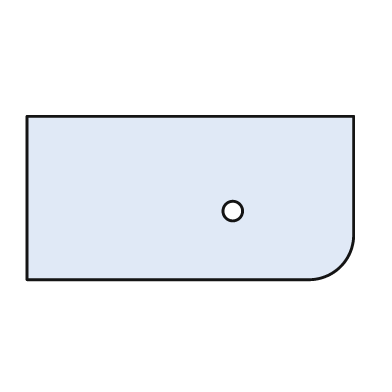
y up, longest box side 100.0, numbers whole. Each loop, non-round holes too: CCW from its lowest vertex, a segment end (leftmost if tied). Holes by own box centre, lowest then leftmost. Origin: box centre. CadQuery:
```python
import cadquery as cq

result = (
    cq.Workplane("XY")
    .moveTo(-50.0, -25.0)
    .lineTo(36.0, -25.0)
    .threePointArc((46.0, -21.0), (50.0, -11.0))
    .lineTo(50.0, 25.0)
    .lineTo(-50.0, 25.0)
    .close()
    .moveTo(13.0, -4.0)
    .circle(3.0)
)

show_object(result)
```